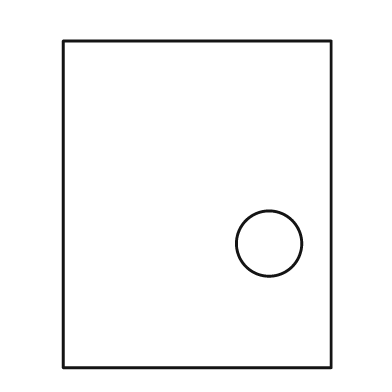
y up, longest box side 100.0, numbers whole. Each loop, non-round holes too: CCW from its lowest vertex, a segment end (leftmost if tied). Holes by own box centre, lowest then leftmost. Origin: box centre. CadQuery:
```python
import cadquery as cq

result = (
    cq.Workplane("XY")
    .moveTo(-41.0, -50.0)
    .lineTo(41.0, -50.0)
    .lineTo(41.0, 50.0)
    .lineTo(-41.0, 50.0)
    .close()
    .moveTo(22.0, -12.0)
    .circle(10.0)
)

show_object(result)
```